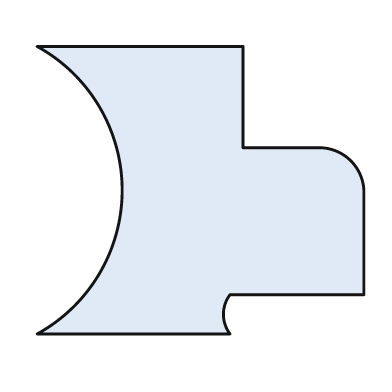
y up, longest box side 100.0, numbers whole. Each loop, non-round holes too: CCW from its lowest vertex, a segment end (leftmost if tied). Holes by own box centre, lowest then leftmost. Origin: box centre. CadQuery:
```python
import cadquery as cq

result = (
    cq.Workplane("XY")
    .moveTo(-50.0, -44.0)
    .lineTo(9.0, -44.0)
    .threePointArc((7.0, -38.0), (9.0, -32.0))
    .lineTo(50.0, -32.0)
    .lineTo(50.0, 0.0)
    .threePointArc((46.0, 9.0), (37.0, 13.0))
    .lineTo(13.0, 13.0)
    .lineTo(13.0, 44.0)
    .lineTo(-50.0, 44.0)
    .threePointArc((-24.0, 0.0), (-50.0, -44.0))
    .close()
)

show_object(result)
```